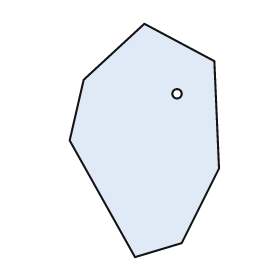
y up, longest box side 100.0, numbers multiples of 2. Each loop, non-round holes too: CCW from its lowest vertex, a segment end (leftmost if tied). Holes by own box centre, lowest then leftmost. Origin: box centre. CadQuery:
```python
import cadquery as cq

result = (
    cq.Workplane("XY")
    .moveTo(-4.0, -50.0)
    .lineTo(16.0, -44.0)
    .lineTo(32.0, -12.0)
    .lineTo(30.0, 34.0)
    .lineTo(0.0, 50.0)
    .lineTo(-26.0, 26.0)
    .lineTo(-32.0, 0.0)
    .close()
    .moveTo(14.0, 20.0)
    .circle(2.0)
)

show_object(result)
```